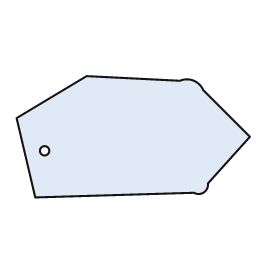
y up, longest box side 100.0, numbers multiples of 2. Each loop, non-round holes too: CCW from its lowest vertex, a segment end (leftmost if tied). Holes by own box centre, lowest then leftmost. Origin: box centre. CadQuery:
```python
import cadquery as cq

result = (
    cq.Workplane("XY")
    .moveTo(-42.0, -26.0)
    .lineTo(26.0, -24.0)
    .threePointArc((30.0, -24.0), (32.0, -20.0))
    .lineTo(50.0, 0.0)
    .lineTo(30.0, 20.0)
    .threePointArc((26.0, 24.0), (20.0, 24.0))
    .lineTo(-20.0, 26.0)
    .lineTo(-50.0, 8.0)
    .close()
    .moveTo(-38.0, -6.0)
    .circle(2.0)
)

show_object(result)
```